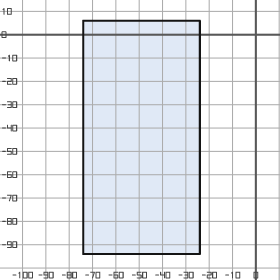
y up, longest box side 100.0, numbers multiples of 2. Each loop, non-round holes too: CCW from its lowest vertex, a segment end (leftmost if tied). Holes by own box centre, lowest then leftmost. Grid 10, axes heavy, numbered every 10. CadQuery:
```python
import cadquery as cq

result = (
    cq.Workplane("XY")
    .moveTo(-74.0, -94.0)
    .lineTo(-24.0, -94.0)
    .lineTo(-24.0, 6.0)
    .lineTo(-74.0, 6.0)
    .close()
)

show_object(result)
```